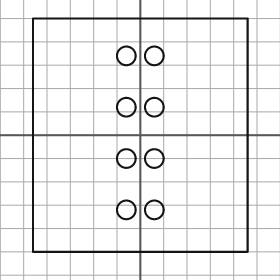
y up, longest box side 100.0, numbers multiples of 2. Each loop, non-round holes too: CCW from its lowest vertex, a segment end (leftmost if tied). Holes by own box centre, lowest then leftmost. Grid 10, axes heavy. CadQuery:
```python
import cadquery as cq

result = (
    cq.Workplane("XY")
    .moveTo(-46.0, -50.0)
    .lineTo(46.0, -50.0)
    .lineTo(46.0, 50.0)
    .lineTo(-46.0, 50.0)
    .close()
    .moveTo(-6.0, -32.0)
    .circle(4.0)
    .moveTo(6.0, -32.0)
    .circle(4.0)
    .moveTo(-6.0, -10.0)
    .circle(4.0)
    .moveTo(6.0, -10.0)
    .circle(4.0)
    .moveTo(-6.0, 12.0)
    .circle(4.0)
    .moveTo(6.0, 12.0)
    .circle(4.0)
    .moveTo(-6.0, 34.0)
    .circle(4.0)
    .moveTo(6.0, 34.0)
    .circle(4.0)
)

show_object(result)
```